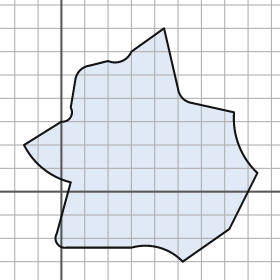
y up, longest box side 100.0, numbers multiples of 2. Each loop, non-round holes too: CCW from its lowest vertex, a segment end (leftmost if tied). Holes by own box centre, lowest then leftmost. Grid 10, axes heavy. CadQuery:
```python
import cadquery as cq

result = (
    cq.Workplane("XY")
    .moveTo(52.0, -30.0)
    .lineTo(72.0, -16.0)
    .lineTo(84.0, 8.0)
    .threePointArc((76.0, 20.0), (74.0, 34.0))
    .lineTo(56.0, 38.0)
    .threePointArc((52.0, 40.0), (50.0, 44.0))
    .lineTo(44.0, 70.0)
    .lineTo(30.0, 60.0)
    .threePointArc((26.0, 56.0), (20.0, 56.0))
    .lineTo(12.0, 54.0)
    .threePointArc((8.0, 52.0), (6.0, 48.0))
    .lineTo(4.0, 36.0)
    .threePointArc((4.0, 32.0), (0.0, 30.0))
    .lineTo(-16.0, 20.0)
    .threePointArc((-8.0, 10.0), (4.0, 4.0))
    .lineTo(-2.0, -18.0)
    .threePointArc((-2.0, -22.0), (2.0, -24.0))
    .lineTo(30.0, -24.0)
    .threePointArc((42.0, -24.0), (52.0, -30.0))
    .close()
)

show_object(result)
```